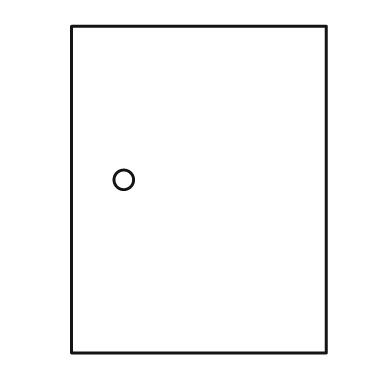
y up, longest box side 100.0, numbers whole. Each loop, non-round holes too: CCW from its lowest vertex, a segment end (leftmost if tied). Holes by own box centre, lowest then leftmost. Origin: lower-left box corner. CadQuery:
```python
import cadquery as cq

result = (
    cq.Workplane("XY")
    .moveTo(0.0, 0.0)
    .lineTo(78.0, 0.0)
    .lineTo(78.0, 100.0)
    .lineTo(0.0, 100.0)
    .close()
    .moveTo(16.0, 53.0)
    .circle(3.0)
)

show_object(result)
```